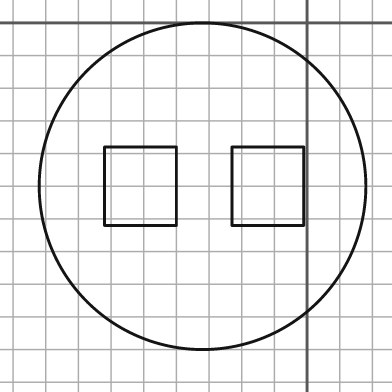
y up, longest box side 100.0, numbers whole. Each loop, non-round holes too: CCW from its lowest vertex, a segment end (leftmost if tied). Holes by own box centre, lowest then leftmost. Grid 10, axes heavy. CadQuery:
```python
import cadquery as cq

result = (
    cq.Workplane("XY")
    .moveTo(-32.0, -50.0)
    .circle(50.0)
    .moveTo(-62.0, -62.0)
    .lineTo(-40.0, -62.0)
    .lineTo(-40.0, -38.0)
    .lineTo(-62.0, -38.0)
    .close()
    .moveTo(-23.0, -62.0)
    .lineTo(-1.0, -62.0)
    .lineTo(-1.0, -38.0)
    .lineTo(-23.0, -38.0)
    .close()
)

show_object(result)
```